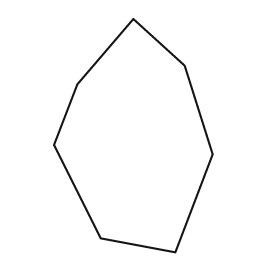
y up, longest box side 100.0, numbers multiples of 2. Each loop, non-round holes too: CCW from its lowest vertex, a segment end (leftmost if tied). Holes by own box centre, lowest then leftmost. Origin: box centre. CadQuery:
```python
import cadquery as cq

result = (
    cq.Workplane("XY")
    .moveTo(18.0, -50.0)
    .lineTo(34.0, -8.0)
    .lineTo(22.0, 30.0)
    .lineTo(0.0, 50.0)
    .lineTo(-24.0, 22.0)
    .lineTo(-34.0, -4.0)
    .lineTo(-14.0, -44.0)
    .close()
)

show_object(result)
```